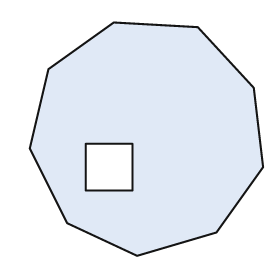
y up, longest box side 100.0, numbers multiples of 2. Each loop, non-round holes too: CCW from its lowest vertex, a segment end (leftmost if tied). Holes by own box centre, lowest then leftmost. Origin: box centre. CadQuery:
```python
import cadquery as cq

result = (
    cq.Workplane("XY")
    .moveTo(-4.0, -50.0)
    .lineTo(30.0, -40.0)
    .lineTo(50.0, -12.0)
    .lineTo(46.0, 22.0)
    .lineTo(22.0, 48.0)
    .lineTo(-14.0, 50.0)
    .lineTo(-42.0, 30.0)
    .lineTo(-50.0, -4.0)
    .lineTo(-34.0, -36.0)
    .close()
    .moveTo(-26.0, -22.0)
    .lineTo(-6.0, -22.0)
    .lineTo(-6.0, -2.0)
    .lineTo(-26.0, -2.0)
    .close()
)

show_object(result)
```